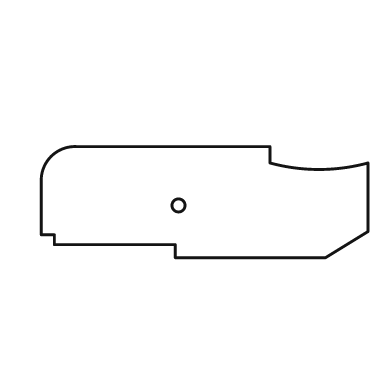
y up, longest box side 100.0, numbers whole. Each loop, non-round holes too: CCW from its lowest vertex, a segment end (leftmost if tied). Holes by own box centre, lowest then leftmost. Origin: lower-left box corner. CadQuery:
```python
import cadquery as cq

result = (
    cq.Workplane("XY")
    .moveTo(41.0, 0.0)
    .lineTo(87.0, 0.0)
    .lineTo(100.0, 8.0)
    .lineTo(100.0, 29.0)
    .threePointArc((85.0, 27.0), (70.0, 29.0))
    .lineTo(70.0, 34.0)
    .lineTo(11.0, 34.0)
    .threePointArc((3.0, 31.0), (0.0, 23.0))
    .lineTo(0.0, 7.0)
    .lineTo(4.0, 7.0)
    .lineTo(4.0, 4.0)
    .lineTo(41.0, 4.0)
    .close()
    .moveTo(42.0, 16.0)
    .circle(2.0)
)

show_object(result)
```